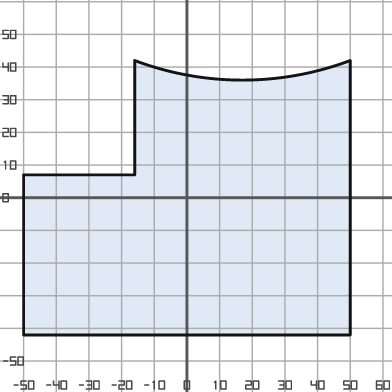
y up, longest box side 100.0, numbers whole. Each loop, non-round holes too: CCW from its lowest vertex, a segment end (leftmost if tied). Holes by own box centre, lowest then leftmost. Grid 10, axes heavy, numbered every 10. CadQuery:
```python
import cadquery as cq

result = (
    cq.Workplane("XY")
    .moveTo(-50.0, -42.0)
    .lineTo(50.0, -42.0)
    .lineTo(50.0, 42.0)
    .threePointArc((17.0, 36.0), (-16.0, 42.0))
    .lineTo(-16.0, 7.0)
    .lineTo(-50.0, 7.0)
    .close()
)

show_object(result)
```